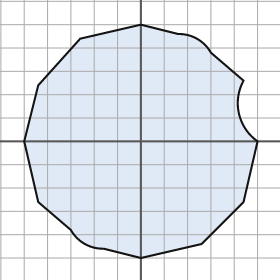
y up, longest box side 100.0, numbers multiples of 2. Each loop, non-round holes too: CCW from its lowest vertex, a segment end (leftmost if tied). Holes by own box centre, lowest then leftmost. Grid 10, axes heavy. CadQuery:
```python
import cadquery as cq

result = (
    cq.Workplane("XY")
    .moveTo(0.0, -50.0)
    .lineTo(26.0, -44.0)
    .lineTo(44.0, -26.0)
    .lineTo(50.0, 0.0)
    .threePointArc((42.0, 12.0), (44.0, 26.0))
    .lineTo(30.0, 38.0)
    .threePointArc((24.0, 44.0), (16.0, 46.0))
    .lineTo(0.0, 50.0)
    .lineTo(-26.0, 44.0)
    .lineTo(-44.0, 24.0)
    .lineTo(-50.0, 0.0)
    .lineTo(-44.0, -26.0)
    .lineTo(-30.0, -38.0)
    .threePointArc((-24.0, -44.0), (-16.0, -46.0))
    .close()
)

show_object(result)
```